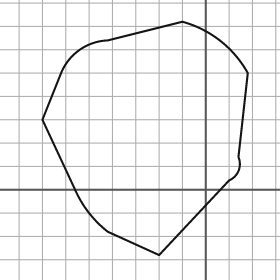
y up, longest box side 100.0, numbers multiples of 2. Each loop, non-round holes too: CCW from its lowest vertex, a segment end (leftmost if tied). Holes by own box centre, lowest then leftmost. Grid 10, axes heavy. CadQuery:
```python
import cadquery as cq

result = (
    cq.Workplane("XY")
    .moveTo(-20.0, -28.0)
    .lineTo(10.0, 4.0)
    .threePointArc((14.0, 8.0), (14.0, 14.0))
    .lineTo(18.0, 50.0)
    .threePointArc((6.0, 64.0), (-10.0, 72.0))
    .lineTo(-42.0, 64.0)
    .threePointArc((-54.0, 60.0), (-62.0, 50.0))
    .lineTo(-70.0, 30.0)
    .lineTo(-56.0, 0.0)
    .threePointArc((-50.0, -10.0), (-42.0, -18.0))
    .close()
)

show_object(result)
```